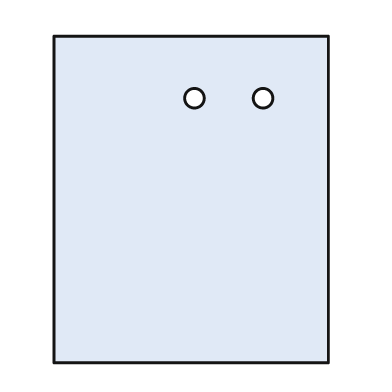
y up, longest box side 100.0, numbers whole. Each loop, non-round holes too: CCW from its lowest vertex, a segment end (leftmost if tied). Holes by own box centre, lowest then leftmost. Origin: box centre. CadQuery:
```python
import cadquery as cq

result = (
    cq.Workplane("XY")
    .moveTo(-42.0, -50.0)
    .lineTo(42.0, -50.0)
    .lineTo(42.0, 50.0)
    .lineTo(-42.0, 50.0)
    .close()
    .moveTo(1.0, 31.0)
    .circle(3.0)
    .moveTo(22.0, 31.0)
    .circle(3.0)
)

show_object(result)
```